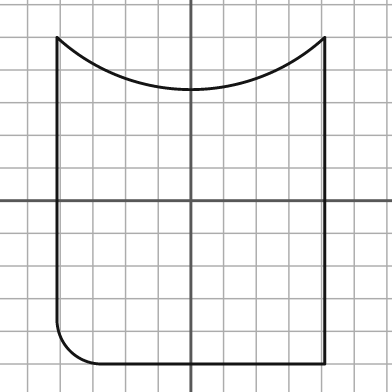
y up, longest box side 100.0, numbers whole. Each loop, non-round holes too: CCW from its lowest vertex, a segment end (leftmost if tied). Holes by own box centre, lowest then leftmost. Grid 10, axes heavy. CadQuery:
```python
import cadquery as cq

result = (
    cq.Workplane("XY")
    .moveTo(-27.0, -50.0)
    .lineTo(41.0, -50.0)
    .lineTo(41.0, 50.0)
    .threePointArc((0.0, 34.0), (-41.0, 50.0))
    .lineTo(-41.0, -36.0)
    .threePointArc((-37.0, -46.0), (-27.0, -50.0))
    .close()
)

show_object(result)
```